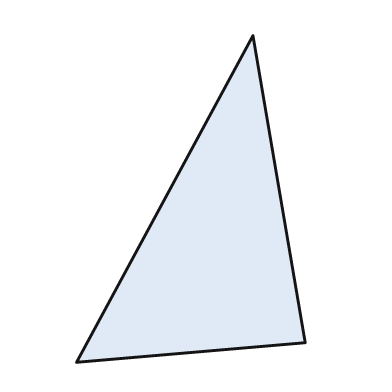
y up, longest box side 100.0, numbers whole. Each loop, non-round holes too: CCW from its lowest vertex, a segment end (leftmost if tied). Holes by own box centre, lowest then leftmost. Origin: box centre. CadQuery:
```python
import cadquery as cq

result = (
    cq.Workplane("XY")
    .moveTo(-35.0, -50.0)
    .lineTo(35.0, -44.0)
    .lineTo(19.0, 50.0)
    .close()
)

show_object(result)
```